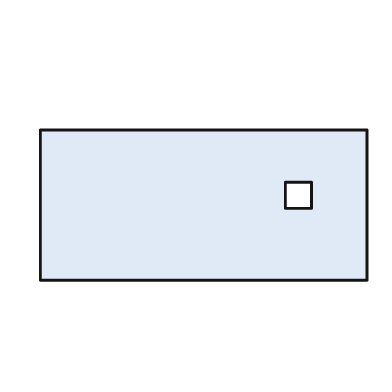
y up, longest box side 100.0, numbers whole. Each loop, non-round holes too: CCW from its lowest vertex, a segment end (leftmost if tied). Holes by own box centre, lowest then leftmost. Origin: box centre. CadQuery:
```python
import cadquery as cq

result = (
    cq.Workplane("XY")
    .moveTo(-50.0, -23.0)
    .lineTo(50.0, -23.0)
    .lineTo(50.0, 23.0)
    .lineTo(-50.0, 23.0)
    .close()
    .moveTo(25.0, -1.0)
    .lineTo(33.0, -1.0)
    .lineTo(33.0, 7.0)
    .lineTo(25.0, 7.0)
    .close()
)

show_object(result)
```